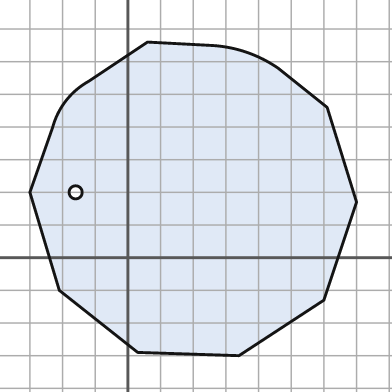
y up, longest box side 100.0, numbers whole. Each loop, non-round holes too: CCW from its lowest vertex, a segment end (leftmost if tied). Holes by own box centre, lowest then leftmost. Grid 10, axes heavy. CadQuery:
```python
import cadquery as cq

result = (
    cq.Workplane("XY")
    .moveTo(34.0, -30.0)
    .lineTo(60.0, -13.0)
    .lineTo(70.0, 17.0)
    .lineTo(61.0, 46.0)
    .lineTo(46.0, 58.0)
    .threePointArc((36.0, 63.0), (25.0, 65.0))
    .lineTo(6.0, 66.0)
    .lineTo(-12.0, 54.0)
    .threePointArc((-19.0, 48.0), (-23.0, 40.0))
    .lineTo(-30.0, 20.0)
    .lineTo(-21.0, -10.0)
    .lineTo(3.0, -29.0)
    .close()
    .moveTo(-16.0, 20.0)
    .circle(2.0)
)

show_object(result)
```